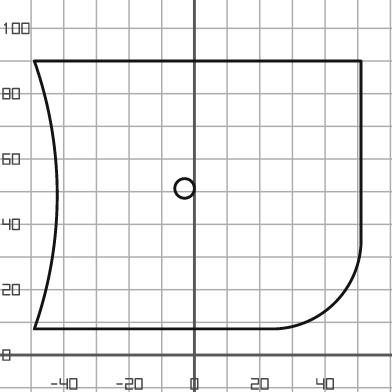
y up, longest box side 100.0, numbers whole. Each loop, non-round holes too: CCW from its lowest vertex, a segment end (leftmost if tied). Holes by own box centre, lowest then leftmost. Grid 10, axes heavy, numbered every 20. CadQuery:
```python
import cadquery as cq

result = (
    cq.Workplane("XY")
    .moveTo(-49.0, 8.0)
    .lineTo(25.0, 8.0)
    .threePointArc((43.0, 16.0), (51.0, 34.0))
    .lineTo(51.0, 90.0)
    .lineTo(-49.0, 90.0)
    .threePointArc((-42.0, 49.0), (-49.0, 8.0))
    .close()
    .moveTo(-3.0, 51.0)
    .circle(3.0)
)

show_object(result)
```